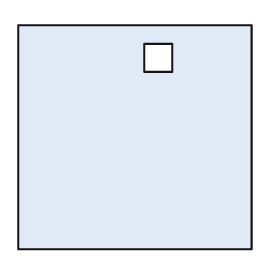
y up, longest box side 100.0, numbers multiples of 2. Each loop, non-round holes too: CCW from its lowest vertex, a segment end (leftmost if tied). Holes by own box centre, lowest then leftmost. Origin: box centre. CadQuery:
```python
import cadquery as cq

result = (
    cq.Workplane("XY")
    .moveTo(-50.0, -48.0)
    .lineTo(50.0, -48.0)
    .lineTo(50.0, 48.0)
    .lineTo(-50.0, 48.0)
    .close()
    .moveTo(4.0, 28.0)
    .lineTo(16.0, 28.0)
    .lineTo(16.0, 40.0)
    .lineTo(4.0, 40.0)
    .close()
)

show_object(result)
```